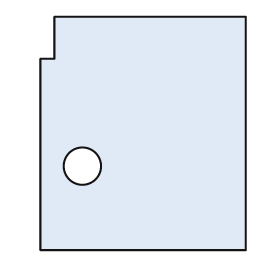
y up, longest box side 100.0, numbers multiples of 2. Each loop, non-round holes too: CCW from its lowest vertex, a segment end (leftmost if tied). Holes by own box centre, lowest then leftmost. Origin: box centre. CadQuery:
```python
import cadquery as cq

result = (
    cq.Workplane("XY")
    .moveTo(-44.0, -50.0)
    .lineTo(44.0, -50.0)
    .lineTo(44.0, 50.0)
    .lineTo(-38.0, 50.0)
    .lineTo(-38.0, 32.0)
    .lineTo(-44.0, 32.0)
    .close()
    .moveTo(-26.0, -14.0)
    .circle(8.0)
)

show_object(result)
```